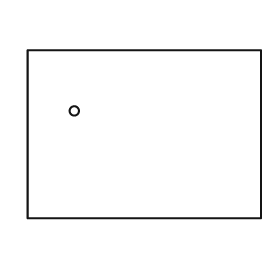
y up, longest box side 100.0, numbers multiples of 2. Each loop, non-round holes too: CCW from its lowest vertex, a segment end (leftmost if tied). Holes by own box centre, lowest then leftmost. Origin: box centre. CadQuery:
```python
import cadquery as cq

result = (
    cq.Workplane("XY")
    .moveTo(-50.0, -36.0)
    .lineTo(50.0, -36.0)
    .lineTo(50.0, 36.0)
    .lineTo(-50.0, 36.0)
    .close()
    .moveTo(-30.0, 10.0)
    .circle(2.0)
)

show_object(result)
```